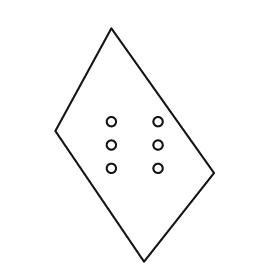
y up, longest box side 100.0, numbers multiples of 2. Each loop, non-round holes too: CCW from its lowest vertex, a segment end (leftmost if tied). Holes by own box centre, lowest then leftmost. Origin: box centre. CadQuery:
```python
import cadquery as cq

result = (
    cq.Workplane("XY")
    .moveTo(4.0, -50.0)
    .lineTo(34.0, -12.0)
    .lineTo(-10.0, 50.0)
    .lineTo(-34.0, 6.0)
    .close()
    .moveTo(-10.0, -10.0)
    .circle(2.0)
    .moveTo(10.0, -10.0)
    .circle(2.0)
    .moveTo(-10.0, 0.0)
    .circle(2.0)
    .moveTo(10.0, 0.0)
    .circle(2.0)
    .moveTo(-10.0, 10.0)
    .circle(2.0)
    .moveTo(10.0, 10.0)
    .circle(2.0)
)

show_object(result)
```